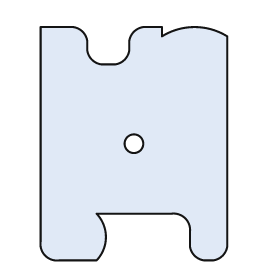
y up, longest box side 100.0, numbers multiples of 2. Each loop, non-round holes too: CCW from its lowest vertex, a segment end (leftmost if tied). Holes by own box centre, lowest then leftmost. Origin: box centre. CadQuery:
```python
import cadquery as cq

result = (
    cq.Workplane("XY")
    .moveTo(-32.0, -50.0)
    .lineTo(-16.0, -50.0)
    .threePointArc((-12.0, -40.0), (-16.0, -30.0))
    .lineTo(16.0, -30.0)
    .threePointArc((22.0, -32.0), (24.0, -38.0))
    .lineTo(24.0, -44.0)
    .threePointArc((26.0, -48.0), (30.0, -50.0))
    .lineTo(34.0, -50.0)
    .threePointArc((38.0, -48.0), (40.0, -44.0))
    .lineTo(40.0, 46.0)
    .threePointArc((26.0, 50.0), (12.0, 46.0))
    .lineTo(12.0, 50.0)
    .lineTo(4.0, 50.0)
    .threePointArc((0.0, 48.0), (-2.0, 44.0))
    .lineTo(-2.0, 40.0)
    .threePointArc((-4.0, 36.0), (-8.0, 34.0))
    .lineTo(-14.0, 34.0)
    .threePointArc((-18.0, 36.0), (-20.0, 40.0))
    .lineTo(-20.0, 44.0)
    .threePointArc((-22.0, 48.0), (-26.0, 50.0))
    .lineTo(-40.0, 50.0)
    .lineTo(-40.0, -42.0)
    .threePointArc((-38.0, -48.0), (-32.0, -50.0))
    .close()
    .moveTo(0.0, 0.0)
    .circle(4.0)
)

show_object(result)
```